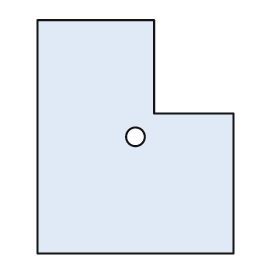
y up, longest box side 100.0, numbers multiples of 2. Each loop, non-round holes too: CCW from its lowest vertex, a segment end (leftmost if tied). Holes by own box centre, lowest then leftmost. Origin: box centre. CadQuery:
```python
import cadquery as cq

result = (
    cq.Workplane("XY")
    .moveTo(-42.0, -50.0)
    .lineTo(42.0, -50.0)
    .lineTo(42.0, 10.0)
    .lineTo(8.0, 10.0)
    .lineTo(8.0, 50.0)
    .lineTo(-42.0, 50.0)
    .close()
    .moveTo(0.0, 0.0)
    .circle(4.0)
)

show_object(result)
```